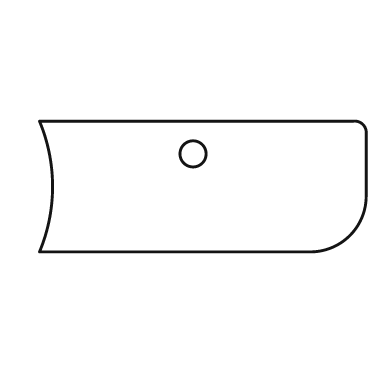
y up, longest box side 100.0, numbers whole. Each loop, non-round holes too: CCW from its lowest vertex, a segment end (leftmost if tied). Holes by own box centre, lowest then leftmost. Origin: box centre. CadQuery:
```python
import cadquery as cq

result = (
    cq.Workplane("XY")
    .moveTo(-50.0, -20.0)
    .lineTo(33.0, -20.0)
    .threePointArc((45.0, -15.0), (50.0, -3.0))
    .lineTo(50.0, 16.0)
    .threePointArc((49.0, 19.0), (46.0, 20.0))
    .lineTo(-50.0, 20.0)
    .threePointArc((-46.0, 0.0), (-50.0, -20.0))
    .close()
    .moveTo(-3.0, 10.0)
    .circle(4.0)
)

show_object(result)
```